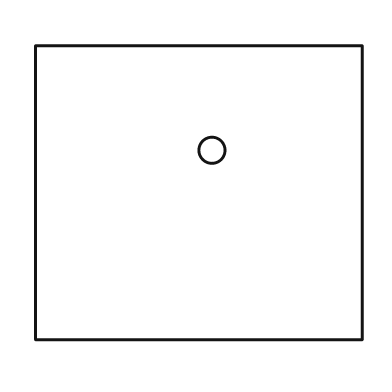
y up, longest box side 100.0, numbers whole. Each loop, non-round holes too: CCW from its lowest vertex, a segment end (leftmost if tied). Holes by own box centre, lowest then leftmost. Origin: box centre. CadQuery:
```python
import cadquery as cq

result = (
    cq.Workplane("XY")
    .moveTo(-50.0, -45.0)
    .lineTo(50.0, -45.0)
    .lineTo(50.0, 45.0)
    .lineTo(-50.0, 45.0)
    .close()
    .moveTo(4.0, 13.0)
    .circle(4.0)
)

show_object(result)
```